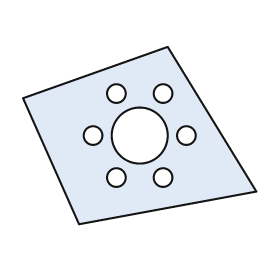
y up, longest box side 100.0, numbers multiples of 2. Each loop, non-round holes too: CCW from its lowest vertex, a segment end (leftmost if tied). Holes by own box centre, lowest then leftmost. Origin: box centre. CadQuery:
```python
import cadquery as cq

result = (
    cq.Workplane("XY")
    .moveTo(-26.0, -38.0)
    .lineTo(50.0, -24.0)
    .lineTo(12.0, 38.0)
    .lineTo(-50.0, 16.0)
    .close()
    .moveTo(-10.0, -18.0)
    .circle(4.0)
    .moveTo(10.0, -18.0)
    .circle(4.0)
    .moveTo(-20.0, 0.0)
    .circle(4.0)
    .moveTo(0.0, 0.0)
    .circle(12.0)
    .moveTo(20.0, 0.0)
    .circle(4.0)
    .moveTo(-10.0, 18.0)
    .circle(4.0)
    .moveTo(10.0, 18.0)
    .circle(4.0)
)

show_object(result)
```